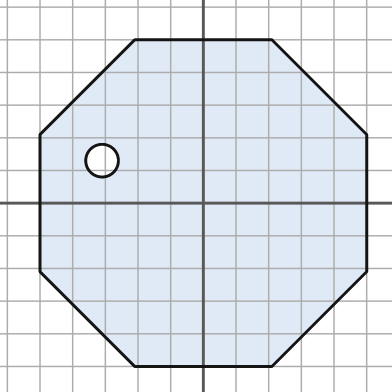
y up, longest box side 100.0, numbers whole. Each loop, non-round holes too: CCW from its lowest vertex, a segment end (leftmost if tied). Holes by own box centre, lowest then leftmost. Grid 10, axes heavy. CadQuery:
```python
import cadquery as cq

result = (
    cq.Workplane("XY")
    .moveTo(-21.0, -50.0)
    .lineTo(21.0, -50.0)
    .lineTo(50.0, -21.0)
    .lineTo(50.0, 21.0)
    .lineTo(21.0, 50.0)
    .lineTo(-21.0, 50.0)
    .lineTo(-50.0, 21.0)
    .lineTo(-50.0, -21.0)
    .close()
    .moveTo(-31.0, 13.0)
    .circle(5.0)
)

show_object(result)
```